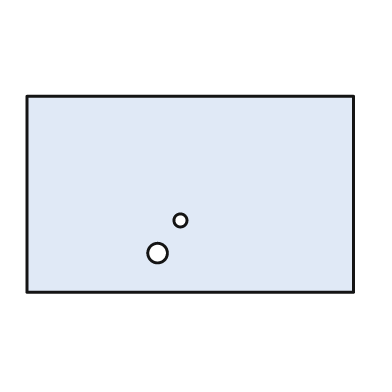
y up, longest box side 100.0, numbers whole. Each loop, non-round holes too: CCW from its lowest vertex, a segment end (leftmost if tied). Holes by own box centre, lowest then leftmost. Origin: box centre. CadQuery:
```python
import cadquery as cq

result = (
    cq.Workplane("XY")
    .moveTo(-50.0, -30.0)
    .lineTo(50.0, -30.0)
    .lineTo(50.0, 30.0)
    .lineTo(-50.0, 30.0)
    .close()
    .moveTo(-10.0, -18.0)
    .circle(3.0)
    .moveTo(-3.0, -8.0)
    .circle(2.0)
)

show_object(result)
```